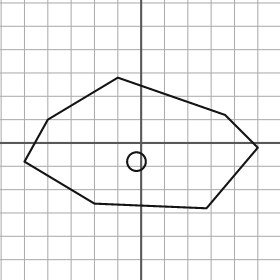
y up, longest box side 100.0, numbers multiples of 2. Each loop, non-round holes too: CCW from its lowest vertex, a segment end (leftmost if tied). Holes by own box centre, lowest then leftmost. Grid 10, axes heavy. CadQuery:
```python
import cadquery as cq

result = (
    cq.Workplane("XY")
    .moveTo(28.0, -28.0)
    .lineTo(50.0, -2.0)
    .lineTo(36.0, 12.0)
    .lineTo(-10.0, 28.0)
    .lineTo(-40.0, 10.0)
    .lineTo(-50.0, -8.0)
    .lineTo(-20.0, -26.0)
    .close()
    .moveTo(-2.0, -8.0)
    .circle(4.0)
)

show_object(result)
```